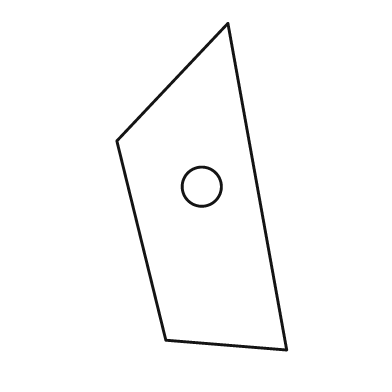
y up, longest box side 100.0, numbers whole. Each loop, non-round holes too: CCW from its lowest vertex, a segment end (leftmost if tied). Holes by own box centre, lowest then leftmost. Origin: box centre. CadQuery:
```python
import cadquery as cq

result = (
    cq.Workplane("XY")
    .moveTo(26.0, -50.0)
    .lineTo(8.0, 50.0)
    .lineTo(-26.0, 14.0)
    .lineTo(-11.0, -47.0)
    .close()
    .moveTo(0.0, 0.0)
    .circle(6.0)
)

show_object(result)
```